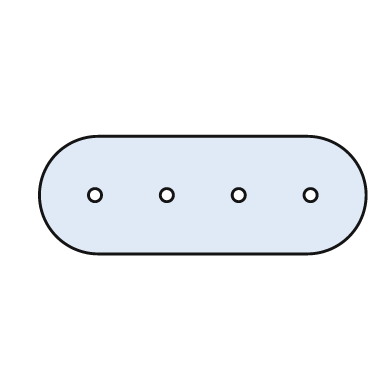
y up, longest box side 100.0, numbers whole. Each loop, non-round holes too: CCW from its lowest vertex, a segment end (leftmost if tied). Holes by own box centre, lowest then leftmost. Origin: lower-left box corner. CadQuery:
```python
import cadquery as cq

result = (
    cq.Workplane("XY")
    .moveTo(18.0, 0.0)
    .lineTo(82.0, 0.0)
    .threePointArc((100.0, 18.0), (82.0, 36.0))
    .lineTo(18.0, 36.0)
    .threePointArc((0.0, 18.0), (18.0, 0.0))
    .close()
    .moveTo(17.0, 18.0)
    .circle(2.0)
    .moveTo(39.0, 18.0)
    .circle(2.0)
    .moveTo(61.0, 18.0)
    .circle(2.0)
    .moveTo(83.0, 18.0)
    .circle(2.0)
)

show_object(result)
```